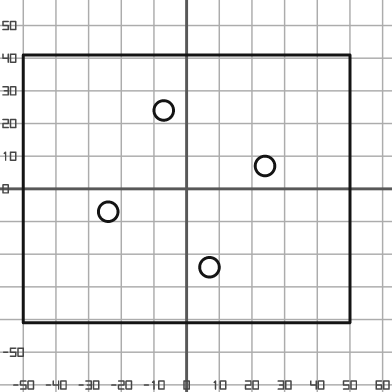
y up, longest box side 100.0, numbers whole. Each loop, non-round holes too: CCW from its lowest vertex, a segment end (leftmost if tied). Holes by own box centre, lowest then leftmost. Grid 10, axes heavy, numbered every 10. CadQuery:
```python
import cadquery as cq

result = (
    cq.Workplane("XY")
    .moveTo(-50.0, -41.0)
    .lineTo(50.0, -41.0)
    .lineTo(50.0, 41.0)
    .lineTo(-50.0, 41.0)
    .close()
    .moveTo(7.0, -24.0)
    .circle(3.0)
    .moveTo(-24.0, -7.0)
    .circle(3.0)
    .moveTo(24.0, 7.0)
    .circle(3.0)
    .moveTo(-7.0, 24.0)
    .circle(3.0)
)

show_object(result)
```